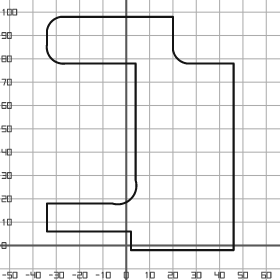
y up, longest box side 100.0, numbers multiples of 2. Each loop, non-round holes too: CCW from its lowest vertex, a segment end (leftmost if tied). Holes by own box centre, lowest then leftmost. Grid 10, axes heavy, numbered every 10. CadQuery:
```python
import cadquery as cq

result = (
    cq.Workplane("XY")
    .moveTo(2.0, -2.0)
    .lineTo(46.0, -2.0)
    .lineTo(46.0, 78.0)
    .lineTo(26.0, 78.0)
    .threePointArc((22.0, 80.0), (20.0, 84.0))
    .lineTo(20.0, 98.0)
    .lineTo(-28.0, 98.0)
    .threePointArc((-32.0, 96.0), (-34.0, 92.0))
    .lineTo(-34.0, 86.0)
    .threePointArc((-32.0, 80.0), (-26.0, 78.0))
    .lineTo(4.0, 78.0)
    .lineTo(4.0, 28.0)
    .threePointArc((2.0, 20.0), (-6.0, 18.0))
    .lineTo(-34.0, 18.0)
    .lineTo(-34.0, 6.0)
    .lineTo(2.0, 6.0)
    .close()
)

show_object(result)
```